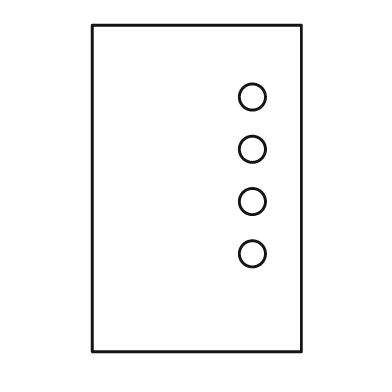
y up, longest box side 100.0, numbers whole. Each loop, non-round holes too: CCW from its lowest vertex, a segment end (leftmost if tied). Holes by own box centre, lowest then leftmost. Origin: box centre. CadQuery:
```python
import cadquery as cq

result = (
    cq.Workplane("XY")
    .moveTo(-32.0, -50.0)
    .lineTo(32.0, -50.0)
    .lineTo(32.0, 50.0)
    .lineTo(-32.0, 50.0)
    .close()
    .moveTo(17.0, -20.0)
    .circle(4.0)
    .moveTo(17.0, -4.0)
    .circle(4.0)
    .moveTo(17.0, 12.0)
    .circle(4.0)
    .moveTo(17.0, 28.0)
    .circle(4.0)
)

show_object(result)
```